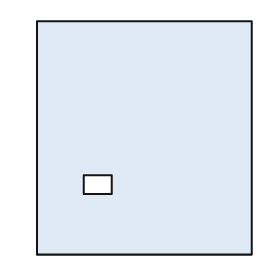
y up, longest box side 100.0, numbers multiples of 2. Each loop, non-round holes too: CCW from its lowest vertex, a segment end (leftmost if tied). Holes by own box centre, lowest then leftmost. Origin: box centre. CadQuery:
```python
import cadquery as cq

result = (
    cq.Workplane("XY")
    .moveTo(-46.0, -50.0)
    .lineTo(46.0, -50.0)
    .lineTo(46.0, 50.0)
    .lineTo(-46.0, 50.0)
    .close()
    .moveTo(-26.0, -24.0)
    .lineTo(-14.0, -24.0)
    .lineTo(-14.0, -16.0)
    .lineTo(-26.0, -16.0)
    .close()
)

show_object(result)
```